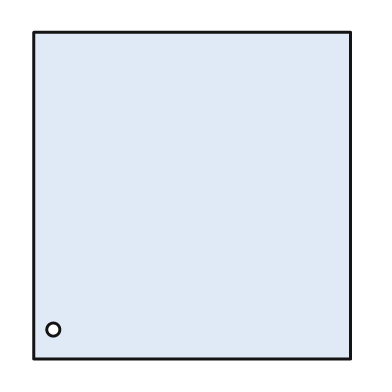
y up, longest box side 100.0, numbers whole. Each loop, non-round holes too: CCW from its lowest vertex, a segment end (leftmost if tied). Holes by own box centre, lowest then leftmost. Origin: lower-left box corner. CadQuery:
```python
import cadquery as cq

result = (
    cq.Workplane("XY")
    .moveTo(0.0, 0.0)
    .lineTo(97.0, 0.0)
    .lineTo(97.0, 100.0)
    .lineTo(0.0, 100.0)
    .close()
    .moveTo(6.0, 9.0)
    .circle(2.0)
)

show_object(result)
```